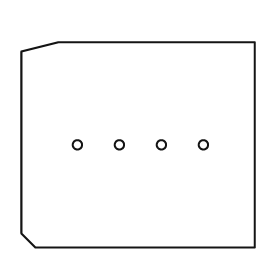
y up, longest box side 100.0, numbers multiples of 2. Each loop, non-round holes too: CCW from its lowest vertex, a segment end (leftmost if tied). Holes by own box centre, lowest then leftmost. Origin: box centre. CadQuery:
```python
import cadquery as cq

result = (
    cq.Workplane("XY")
    .moveTo(-44.0, -44.0)
    .lineTo(50.0, -44.0)
    .lineTo(50.0, 44.0)
    .lineTo(-34.0, 44.0)
    .lineTo(-50.0, 40.0)
    .lineTo(-50.0, -38.0)
    .close()
    .moveTo(-26.0, 0.0)
    .circle(2.0)
    .moveTo(-8.0, 0.0)
    .circle(2.0)
    .moveTo(10.0, 0.0)
    .circle(2.0)
    .moveTo(28.0, 0.0)
    .circle(2.0)
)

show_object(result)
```